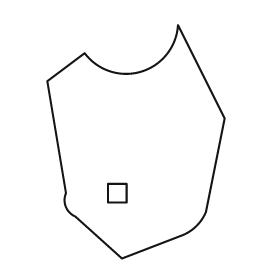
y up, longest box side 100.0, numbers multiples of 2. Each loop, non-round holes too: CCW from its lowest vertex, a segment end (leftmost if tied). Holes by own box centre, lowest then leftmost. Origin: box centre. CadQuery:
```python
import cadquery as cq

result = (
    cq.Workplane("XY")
    .moveTo(-6.0, -50.0)
    .lineTo(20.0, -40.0)
    .threePointArc((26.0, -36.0), (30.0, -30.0))
    .lineTo(38.0, 10.0)
    .lineTo(18.0, 50.0)
    .threePointArc((2.0, 30.0), (-22.0, 38.0))
    .lineTo(-38.0, 26.0)
    .lineTo(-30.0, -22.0)
    .threePointArc((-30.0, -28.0), (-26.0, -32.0))
    .close()
    .moveTo(-12.0, -26.0)
    .lineTo(-4.0, -26.0)
    .lineTo(-4.0, -18.0)
    .lineTo(-12.0, -18.0)
    .close()
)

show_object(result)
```